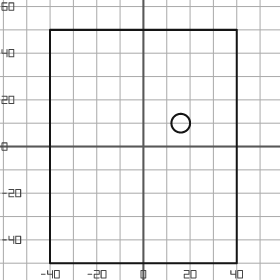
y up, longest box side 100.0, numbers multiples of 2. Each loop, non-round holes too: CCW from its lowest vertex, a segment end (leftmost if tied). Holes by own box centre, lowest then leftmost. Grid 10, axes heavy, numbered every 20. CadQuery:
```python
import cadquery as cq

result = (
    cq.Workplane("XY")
    .moveTo(-40.0, -50.0)
    .lineTo(40.0, -50.0)
    .lineTo(40.0, 50.0)
    .lineTo(-40.0, 50.0)
    .close()
    .moveTo(16.0, 10.0)
    .circle(4.0)
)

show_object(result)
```